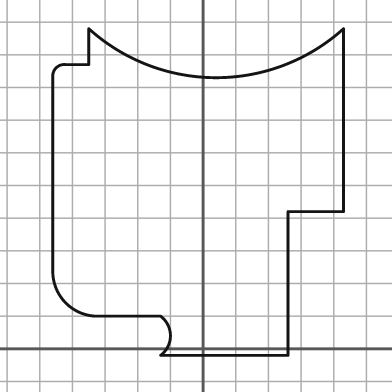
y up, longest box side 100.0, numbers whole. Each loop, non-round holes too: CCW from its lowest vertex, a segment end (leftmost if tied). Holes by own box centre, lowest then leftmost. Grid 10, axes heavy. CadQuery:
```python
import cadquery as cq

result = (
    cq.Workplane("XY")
    .moveTo(-13.0, -2.0)
    .lineTo(26.0, -2.0)
    .lineTo(26.0, 42.0)
    .lineTo(43.0, 42.0)
    .lineTo(43.0, 98.0)
    .threePointArc((4.0, 83.0), (-35.0, 98.0))
    .lineTo(-35.0, 87.0)
    .lineTo(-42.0, 87.0)
    .threePointArc((-45.0, 86.0), (-46.0, 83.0))
    .lineTo(-46.0, 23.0)
    .threePointArc((-42.0, 14.0), (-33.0, 10.0))
    .lineTo(-13.0, 10.0)
    .threePointArc((-10.0, 4.0), (-13.0, -2.0))
    .close()
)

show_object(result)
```